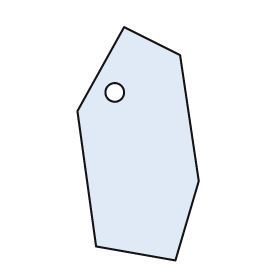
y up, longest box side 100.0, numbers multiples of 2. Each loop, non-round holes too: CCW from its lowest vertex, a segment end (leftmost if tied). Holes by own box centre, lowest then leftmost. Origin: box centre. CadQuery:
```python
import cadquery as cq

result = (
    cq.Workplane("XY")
    .moveTo(16.0, -50.0)
    .lineTo(26.0, -16.0)
    .lineTo(18.0, 38.0)
    .lineTo(-6.0, 50.0)
    .lineTo(-26.0, 14.0)
    .lineTo(-18.0, -44.0)
    .close()
    .moveTo(-10.0, 22.0)
    .circle(4.0)
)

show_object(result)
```